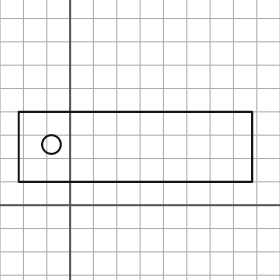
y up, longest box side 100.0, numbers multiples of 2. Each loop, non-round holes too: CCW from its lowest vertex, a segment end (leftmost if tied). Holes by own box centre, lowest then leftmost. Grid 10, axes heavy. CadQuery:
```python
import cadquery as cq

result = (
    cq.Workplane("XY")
    .moveTo(-22.0, 10.0)
    .lineTo(78.0, 10.0)
    .lineTo(78.0, 40.0)
    .lineTo(-22.0, 40.0)
    .close()
    .moveTo(-8.0, 26.0)
    .circle(4.0)
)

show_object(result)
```